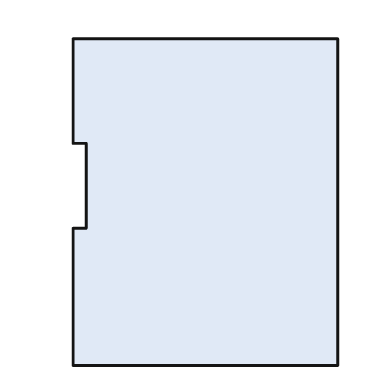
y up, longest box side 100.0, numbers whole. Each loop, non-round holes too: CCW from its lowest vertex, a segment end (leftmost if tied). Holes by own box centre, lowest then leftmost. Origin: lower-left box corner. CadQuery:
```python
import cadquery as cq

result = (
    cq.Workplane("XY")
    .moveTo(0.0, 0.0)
    .lineTo(81.0, 0.0)
    .lineTo(81.0, 100.0)
    .lineTo(0.0, 100.0)
    .lineTo(0.0, 68.0)
    .lineTo(4.0, 68.0)
    .lineTo(4.0, 42.0)
    .lineTo(0.0, 42.0)
    .close()
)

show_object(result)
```